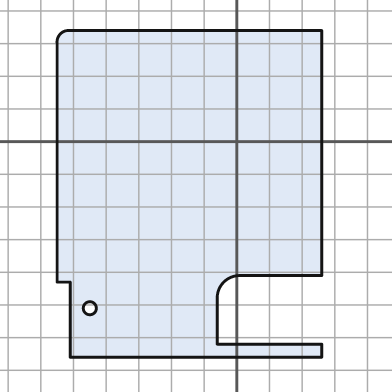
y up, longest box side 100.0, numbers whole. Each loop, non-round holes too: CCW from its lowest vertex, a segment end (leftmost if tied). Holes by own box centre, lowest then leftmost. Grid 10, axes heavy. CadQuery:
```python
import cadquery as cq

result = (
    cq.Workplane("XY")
    .moveTo(-51.0, -66.0)
    .lineTo(26.0, -66.0)
    .lineTo(26.0, -62.0)
    .lineTo(-6.0, -62.0)
    .lineTo(-6.0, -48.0)
    .threePointArc((-4.0, -43.0), (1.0, -41.0))
    .lineTo(26.0, -41.0)
    .lineTo(26.0, 34.0)
    .lineTo(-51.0, 34.0)
    .threePointArc((-54.0, 33.0), (-55.0, 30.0))
    .lineTo(-55.0, -43.0)
    .lineTo(-51.0, -43.0)
    .close()
    .moveTo(-45.0, -51.0)
    .circle(2.0)
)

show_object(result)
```